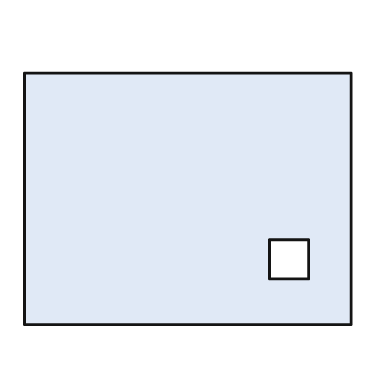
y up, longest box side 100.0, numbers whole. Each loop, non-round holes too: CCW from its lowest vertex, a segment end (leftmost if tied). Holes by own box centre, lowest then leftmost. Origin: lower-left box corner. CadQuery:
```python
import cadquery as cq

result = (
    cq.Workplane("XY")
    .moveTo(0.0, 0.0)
    .lineTo(100.0, 0.0)
    .lineTo(100.0, 77.0)
    .lineTo(0.0, 77.0)
    .close()
    .moveTo(75.0, 14.0)
    .lineTo(87.0, 14.0)
    .lineTo(87.0, 26.0)
    .lineTo(75.0, 26.0)
    .close()
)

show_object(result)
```